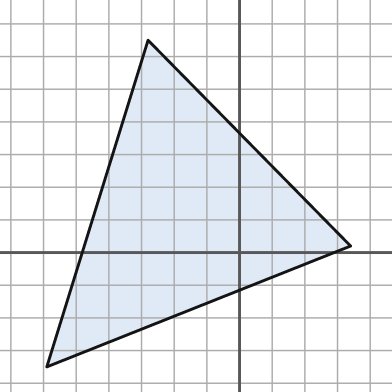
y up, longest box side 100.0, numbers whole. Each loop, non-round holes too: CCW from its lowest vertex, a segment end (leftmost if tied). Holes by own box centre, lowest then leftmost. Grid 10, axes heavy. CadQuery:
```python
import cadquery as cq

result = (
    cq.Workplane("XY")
    .moveTo(-59.0, -35.0)
    .lineTo(34.0, 2.0)
    .lineTo(-28.0, 65.0)
    .close()
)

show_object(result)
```